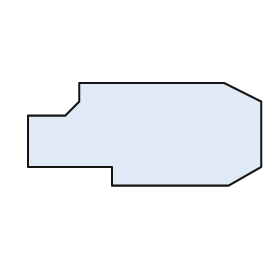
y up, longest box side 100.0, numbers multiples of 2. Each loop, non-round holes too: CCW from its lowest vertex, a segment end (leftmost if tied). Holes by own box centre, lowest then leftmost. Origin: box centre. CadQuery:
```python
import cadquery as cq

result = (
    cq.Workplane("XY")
    .moveTo(-14.0, -22.0)
    .lineTo(36.0, -22.0)
    .lineTo(50.0, -14.0)
    .lineTo(50.0, 14.0)
    .lineTo(34.0, 22.0)
    .lineTo(-28.0, 22.0)
    .lineTo(-28.0, 14.0)
    .lineTo(-34.0, 8.0)
    .lineTo(-50.0, 8.0)
    .lineTo(-50.0, -14.0)
    .lineTo(-14.0, -14.0)
    .close()
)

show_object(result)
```